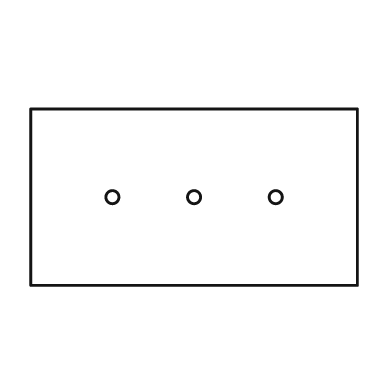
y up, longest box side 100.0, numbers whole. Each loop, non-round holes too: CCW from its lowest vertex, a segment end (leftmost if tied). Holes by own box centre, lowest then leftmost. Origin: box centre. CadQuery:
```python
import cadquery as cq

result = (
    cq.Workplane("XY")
    .moveTo(-50.0, -27.0)
    .lineTo(50.0, -27.0)
    .lineTo(50.0, 27.0)
    .lineTo(-50.0, 27.0)
    .close()
    .moveTo(-25.0, 0.0)
    .circle(2.0)
    .moveTo(0.0, 0.0)
    .circle(2.0)
    .moveTo(25.0, 0.0)
    .circle(2.0)
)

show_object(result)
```